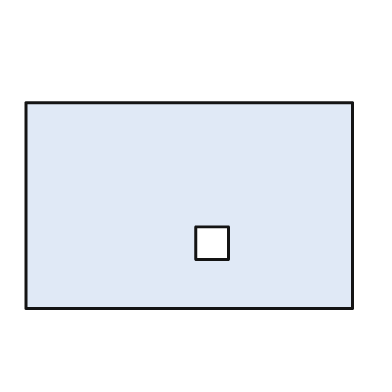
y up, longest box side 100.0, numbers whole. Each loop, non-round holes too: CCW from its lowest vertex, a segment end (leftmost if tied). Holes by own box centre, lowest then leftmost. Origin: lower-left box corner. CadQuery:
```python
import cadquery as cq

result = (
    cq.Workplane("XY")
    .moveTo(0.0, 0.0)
    .lineTo(100.0, 0.0)
    .lineTo(100.0, 63.0)
    .lineTo(0.0, 63.0)
    .close()
    .moveTo(52.0, 15.0)
    .lineTo(62.0, 15.0)
    .lineTo(62.0, 25.0)
    .lineTo(52.0, 25.0)
    .close()
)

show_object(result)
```